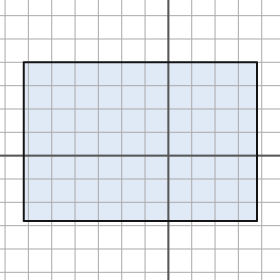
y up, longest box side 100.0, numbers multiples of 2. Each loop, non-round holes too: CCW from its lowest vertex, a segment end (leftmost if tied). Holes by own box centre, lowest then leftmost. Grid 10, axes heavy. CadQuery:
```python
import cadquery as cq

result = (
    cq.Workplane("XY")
    .moveTo(-62.0, -28.0)
    .lineTo(38.0, -28.0)
    .lineTo(38.0, 40.0)
    .lineTo(-62.0, 40.0)
    .close()
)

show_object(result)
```